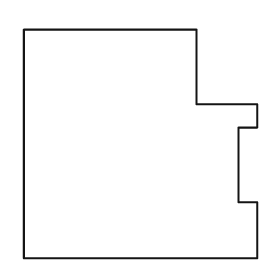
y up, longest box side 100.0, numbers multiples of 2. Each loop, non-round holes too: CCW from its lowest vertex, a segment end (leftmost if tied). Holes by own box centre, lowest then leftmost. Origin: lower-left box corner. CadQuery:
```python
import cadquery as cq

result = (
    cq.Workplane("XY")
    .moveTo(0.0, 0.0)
    .lineTo(100.0, 0.0)
    .lineTo(100.0, 24.0)
    .lineTo(92.0, 24.0)
    .lineTo(92.0, 56.0)
    .lineTo(100.0, 56.0)
    .lineTo(100.0, 66.0)
    .lineTo(74.0, 66.0)
    .lineTo(74.0, 98.0)
    .lineTo(0.0, 98.0)
    .close()
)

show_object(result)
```